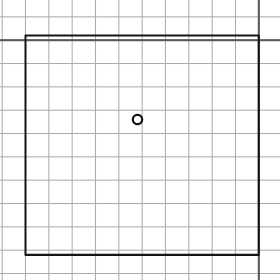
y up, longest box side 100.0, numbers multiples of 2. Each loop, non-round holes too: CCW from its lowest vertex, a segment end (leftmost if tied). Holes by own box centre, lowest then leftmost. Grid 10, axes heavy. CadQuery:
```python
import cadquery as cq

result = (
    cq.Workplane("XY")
    .moveTo(-100.0, -92.0)
    .lineTo(0.0, -92.0)
    .lineTo(0.0, 2.0)
    .lineTo(-100.0, 2.0)
    .close()
    .moveTo(-52.0, -34.0)
    .circle(2.0)
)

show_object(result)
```